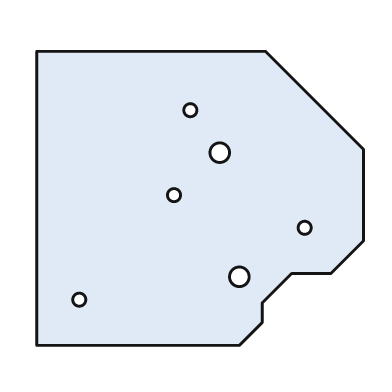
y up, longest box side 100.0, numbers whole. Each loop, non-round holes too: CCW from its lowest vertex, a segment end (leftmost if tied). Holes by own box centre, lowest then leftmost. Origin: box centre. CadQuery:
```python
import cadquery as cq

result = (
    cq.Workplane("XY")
    .moveTo(-50.0, -45.0)
    .lineTo(12.0, -45.0)
    .lineTo(19.0, -38.0)
    .lineTo(19.0, -32.0)
    .lineTo(28.0, -23.0)
    .lineTo(40.0, -23.0)
    .lineTo(50.0, -13.0)
    .lineTo(50.0, 15.0)
    .lineTo(20.0, 45.0)
    .lineTo(-50.0, 45.0)
    .close()
    .moveTo(-37.0, -31.0)
    .circle(2.0)
    .moveTo(12.0, -24.0)
    .circle(3.0)
    .moveTo(32.0, -9.0)
    .circle(2.0)
    .moveTo(-8.0, 1.0)
    .circle(2.0)
    .moveTo(6.0, 14.0)
    .circle(3.0)
    .moveTo(-3.0, 27.0)
    .circle(2.0)
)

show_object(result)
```